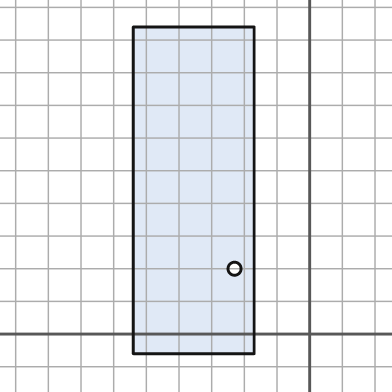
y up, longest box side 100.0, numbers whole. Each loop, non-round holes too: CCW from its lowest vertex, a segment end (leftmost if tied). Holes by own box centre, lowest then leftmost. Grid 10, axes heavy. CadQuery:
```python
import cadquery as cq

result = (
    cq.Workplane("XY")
    .moveTo(-54.0, -6.0)
    .lineTo(-17.0, -6.0)
    .lineTo(-17.0, 94.0)
    .lineTo(-54.0, 94.0)
    .close()
    .moveTo(-23.0, 20.0)
    .circle(2.0)
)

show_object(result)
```